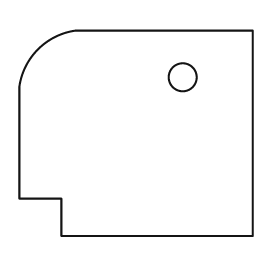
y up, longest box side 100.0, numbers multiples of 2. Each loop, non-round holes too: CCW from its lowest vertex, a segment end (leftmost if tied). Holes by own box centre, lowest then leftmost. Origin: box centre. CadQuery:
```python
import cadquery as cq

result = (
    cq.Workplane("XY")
    .moveTo(-32.0, -44.0)
    .lineTo(50.0, -44.0)
    .lineTo(50.0, 44.0)
    .lineTo(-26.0, 44.0)
    .threePointArc((-42.0, 36.0), (-50.0, 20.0))
    .lineTo(-50.0, -28.0)
    .lineTo(-32.0, -28.0)
    .close()
    .moveTo(20.0, 24.0)
    .circle(6.0)
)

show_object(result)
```